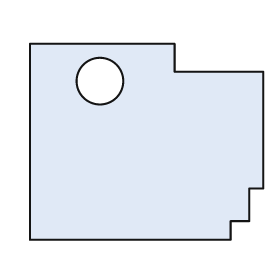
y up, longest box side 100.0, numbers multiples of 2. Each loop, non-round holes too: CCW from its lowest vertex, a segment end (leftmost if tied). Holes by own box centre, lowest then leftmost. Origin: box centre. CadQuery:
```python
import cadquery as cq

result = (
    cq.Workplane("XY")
    .moveTo(-50.0, -42.0)
    .lineTo(36.0, -42.0)
    .lineTo(36.0, -34.0)
    .lineTo(44.0, -34.0)
    .lineTo(44.0, -20.0)
    .lineTo(50.0, -20.0)
    .lineTo(50.0, 30.0)
    .lineTo(12.0, 30.0)
    .lineTo(12.0, 42.0)
    .lineTo(-50.0, 42.0)
    .close()
    .moveTo(-20.0, 26.0)
    .circle(10.0)
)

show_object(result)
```